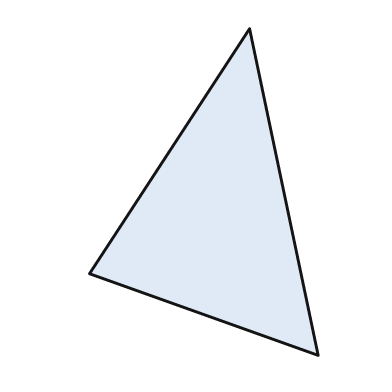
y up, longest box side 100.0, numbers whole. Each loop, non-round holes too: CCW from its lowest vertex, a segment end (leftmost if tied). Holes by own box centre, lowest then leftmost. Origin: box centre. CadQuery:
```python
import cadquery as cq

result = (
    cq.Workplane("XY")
    .moveTo(35.0, -50.0)
    .lineTo(14.0, 50.0)
    .lineTo(-35.0, -25.0)
    .close()
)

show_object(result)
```